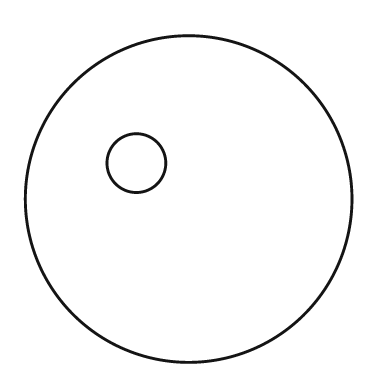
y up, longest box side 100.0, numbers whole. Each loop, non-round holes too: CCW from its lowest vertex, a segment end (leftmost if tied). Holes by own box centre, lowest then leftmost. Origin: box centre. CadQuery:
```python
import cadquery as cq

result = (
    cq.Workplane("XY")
    .moveTo(0.0, 0.0)
    .circle(50.0)
    .moveTo(-16.0, 11.0)
    .circle(9.0)
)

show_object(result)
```